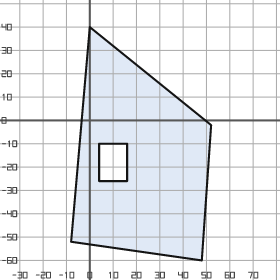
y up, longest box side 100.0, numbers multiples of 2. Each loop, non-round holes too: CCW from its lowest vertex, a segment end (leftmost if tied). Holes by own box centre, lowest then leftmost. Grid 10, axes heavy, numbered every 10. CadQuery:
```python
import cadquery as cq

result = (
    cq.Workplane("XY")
    .moveTo(48.0, -60.0)
    .lineTo(52.0, -2.0)
    .lineTo(0.0, 40.0)
    .lineTo(-8.0, -52.0)
    .close()
    .moveTo(4.0, -26.0)
    .lineTo(16.0, -26.0)
    .lineTo(16.0, -10.0)
    .lineTo(4.0, -10.0)
    .close()
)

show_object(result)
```